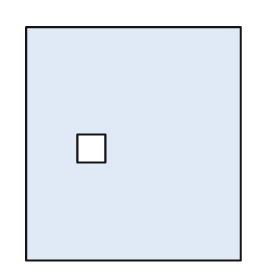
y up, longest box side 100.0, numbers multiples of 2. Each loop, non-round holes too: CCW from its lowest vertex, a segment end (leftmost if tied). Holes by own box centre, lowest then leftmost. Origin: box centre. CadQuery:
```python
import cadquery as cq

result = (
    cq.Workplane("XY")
    .moveTo(-46.0, -50.0)
    .lineTo(46.0, -50.0)
    .lineTo(46.0, 50.0)
    .lineTo(-46.0, 50.0)
    .close()
    .moveTo(-24.0, -8.0)
    .lineTo(-12.0, -8.0)
    .lineTo(-12.0, 4.0)
    .lineTo(-24.0, 4.0)
    .close()
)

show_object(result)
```